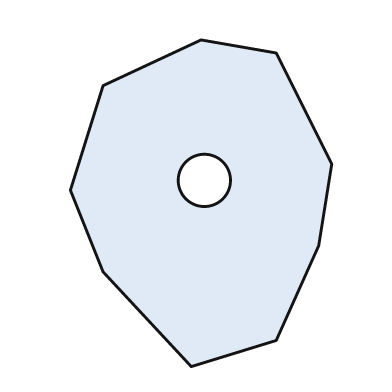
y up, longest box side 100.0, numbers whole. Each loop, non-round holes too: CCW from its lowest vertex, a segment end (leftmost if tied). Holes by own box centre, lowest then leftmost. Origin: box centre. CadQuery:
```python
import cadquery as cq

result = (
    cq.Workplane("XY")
    .moveTo(-3.0, -50.0)
    .lineTo(23.0, -42.0)
    .lineTo(36.0, -13.0)
    .lineTo(40.0, 12.0)
    .lineTo(23.0, 46.0)
    .lineTo(0.0, 50.0)
    .lineTo(-30.0, 36.0)
    .lineTo(-40.0, 4.0)
    .lineTo(-30.0, -21.0)
    .close()
    .moveTo(1.0, 7.0)
    .circle(8.0)
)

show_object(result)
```